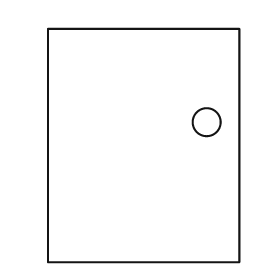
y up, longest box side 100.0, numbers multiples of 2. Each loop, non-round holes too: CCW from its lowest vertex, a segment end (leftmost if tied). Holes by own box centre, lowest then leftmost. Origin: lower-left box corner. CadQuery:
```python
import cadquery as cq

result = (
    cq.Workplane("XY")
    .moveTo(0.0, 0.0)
    .lineTo(82.0, 0.0)
    .lineTo(82.0, 100.0)
    .lineTo(0.0, 100.0)
    .close()
    .moveTo(68.0, 60.0)
    .circle(6.0)
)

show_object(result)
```